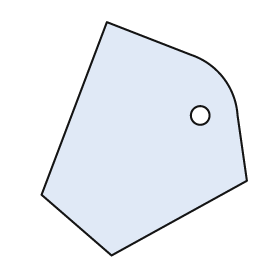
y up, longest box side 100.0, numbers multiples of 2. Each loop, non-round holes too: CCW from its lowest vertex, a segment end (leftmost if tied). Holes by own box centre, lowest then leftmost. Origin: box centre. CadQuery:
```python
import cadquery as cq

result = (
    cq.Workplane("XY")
    .moveTo(-14.0, -50.0)
    .lineTo(44.0, -18.0)
    .lineTo(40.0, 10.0)
    .threePointArc((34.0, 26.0), (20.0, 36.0))
    .lineTo(-16.0, 50.0)
    .lineTo(-44.0, -24.0)
    .close()
    .moveTo(24.0, 10.0)
    .circle(4.0)
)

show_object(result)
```